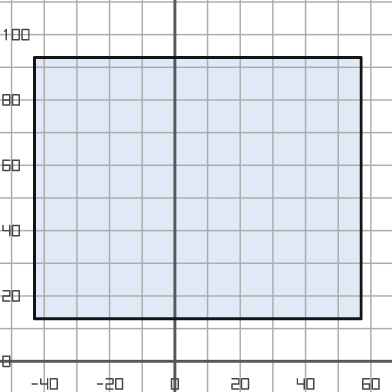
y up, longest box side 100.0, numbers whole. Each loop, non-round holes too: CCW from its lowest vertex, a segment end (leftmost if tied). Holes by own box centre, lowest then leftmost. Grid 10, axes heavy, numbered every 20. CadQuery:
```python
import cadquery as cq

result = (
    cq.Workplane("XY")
    .moveTo(-43.0, 13.0)
    .lineTo(57.0, 13.0)
    .lineTo(57.0, 93.0)
    .lineTo(-43.0, 93.0)
    .close()
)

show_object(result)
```